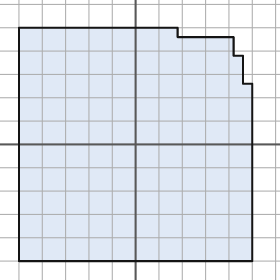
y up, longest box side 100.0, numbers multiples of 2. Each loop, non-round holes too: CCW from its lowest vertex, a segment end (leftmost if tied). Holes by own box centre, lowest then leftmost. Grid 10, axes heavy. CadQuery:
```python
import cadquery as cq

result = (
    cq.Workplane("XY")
    .moveTo(-50.0, -50.0)
    .lineTo(50.0, -50.0)
    .lineTo(50.0, 26.0)
    .lineTo(46.0, 26.0)
    .lineTo(46.0, 38.0)
    .lineTo(42.0, 38.0)
    .lineTo(42.0, 46.0)
    .lineTo(18.0, 46.0)
    .lineTo(18.0, 50.0)
    .lineTo(-50.0, 50.0)
    .close()
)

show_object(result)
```